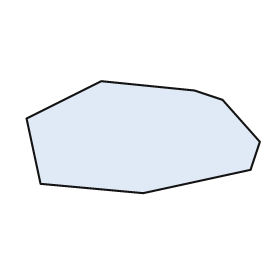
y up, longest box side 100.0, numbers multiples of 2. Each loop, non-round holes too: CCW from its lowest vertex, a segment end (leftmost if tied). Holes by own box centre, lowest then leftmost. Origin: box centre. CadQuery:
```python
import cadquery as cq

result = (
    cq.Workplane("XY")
    .moveTo(0.0, -24.0)
    .lineTo(46.0, -14.0)
    .lineTo(50.0, -2.0)
    .lineTo(34.0, 16.0)
    .lineTo(22.0, 20.0)
    .lineTo(-18.0, 24.0)
    .lineTo(-50.0, 8.0)
    .lineTo(-44.0, -20.0)
    .close()
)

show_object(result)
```